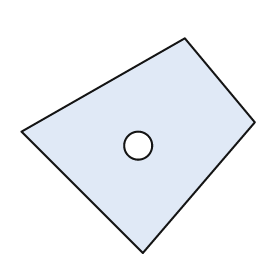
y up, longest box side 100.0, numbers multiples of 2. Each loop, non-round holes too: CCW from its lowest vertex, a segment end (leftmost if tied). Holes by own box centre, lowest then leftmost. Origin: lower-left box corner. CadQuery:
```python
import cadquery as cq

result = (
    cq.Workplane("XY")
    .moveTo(52.0, 0.0)
    .lineTo(100.0, 56.0)
    .lineTo(70.0, 92.0)
    .lineTo(0.0, 52.0)
    .close()
    .moveTo(50.0, 46.0)
    .circle(6.0)
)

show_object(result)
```